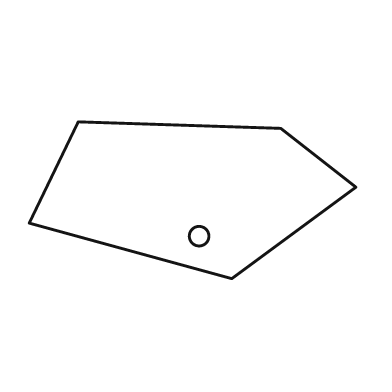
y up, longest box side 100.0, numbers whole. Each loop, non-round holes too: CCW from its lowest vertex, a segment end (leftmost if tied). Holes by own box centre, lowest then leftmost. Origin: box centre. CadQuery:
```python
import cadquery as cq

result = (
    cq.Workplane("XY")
    .moveTo(12.0, -24.0)
    .lineTo(50.0, 4.0)
    .lineTo(27.0, 22.0)
    .lineTo(-35.0, 24.0)
    .lineTo(-50.0, -7.0)
    .close()
    .moveTo(2.0, -11.0)
    .circle(3.0)
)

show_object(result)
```